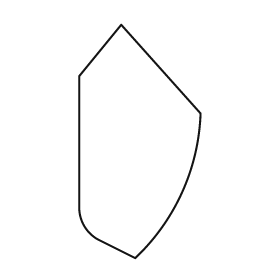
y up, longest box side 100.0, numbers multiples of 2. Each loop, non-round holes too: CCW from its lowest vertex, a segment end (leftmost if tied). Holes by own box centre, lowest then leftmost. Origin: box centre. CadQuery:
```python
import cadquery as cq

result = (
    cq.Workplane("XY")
    .moveTo(-2.0, -50.0)
    .threePointArc((18.0, -22.0), (26.0, 12.0))
    .lineTo(-8.0, 50.0)
    .lineTo(-26.0, 28.0)
    .lineTo(-26.0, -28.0)
    .threePointArc((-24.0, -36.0), (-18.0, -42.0))
    .close()
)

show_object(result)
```